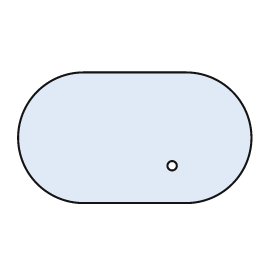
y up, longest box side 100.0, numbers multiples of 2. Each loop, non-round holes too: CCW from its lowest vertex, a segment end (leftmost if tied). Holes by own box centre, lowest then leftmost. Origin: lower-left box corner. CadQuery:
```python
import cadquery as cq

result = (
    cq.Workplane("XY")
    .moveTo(28.0, 0.0)
    .lineTo(72.0, 0.0)
    .threePointArc((100.0, 28.0), (72.0, 56.0))
    .lineTo(28.0, 56.0)
    .threePointArc((0.0, 28.0), (28.0, 0.0))
    .close()
    .moveTo(66.0, 16.0)
    .circle(2.0)
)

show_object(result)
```